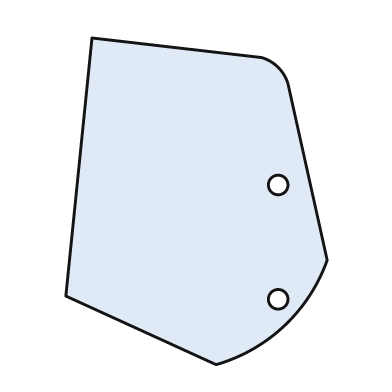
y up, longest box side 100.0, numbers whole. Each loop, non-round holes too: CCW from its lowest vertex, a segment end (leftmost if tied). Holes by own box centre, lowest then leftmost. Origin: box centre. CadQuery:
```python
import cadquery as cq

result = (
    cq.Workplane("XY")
    .moveTo(6.0, -50.0)
    .threePointArc((27.0, -38.0), (40.0, -18.0))
    .lineTo(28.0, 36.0)
    .threePointArc((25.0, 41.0), (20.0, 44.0))
    .lineTo(-32.0, 50.0)
    .lineTo(-40.0, -29.0)
    .close()
    .moveTo(25.0, -30.0)
    .circle(3.0)
    .moveTo(25.0, 5.0)
    .circle(3.0)
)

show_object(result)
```